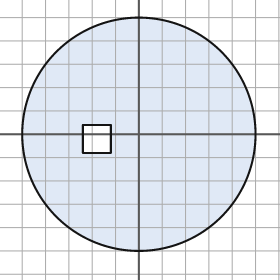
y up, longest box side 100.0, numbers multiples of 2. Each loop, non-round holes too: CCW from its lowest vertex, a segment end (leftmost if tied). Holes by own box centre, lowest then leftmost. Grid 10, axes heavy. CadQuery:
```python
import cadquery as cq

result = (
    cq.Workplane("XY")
    .moveTo(0.0, 0.0)
    .circle(50.0)
    .moveTo(-24.0, -8.0)
    .lineTo(-12.0, -8.0)
    .lineTo(-12.0, 4.0)
    .lineTo(-24.0, 4.0)
    .close()
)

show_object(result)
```